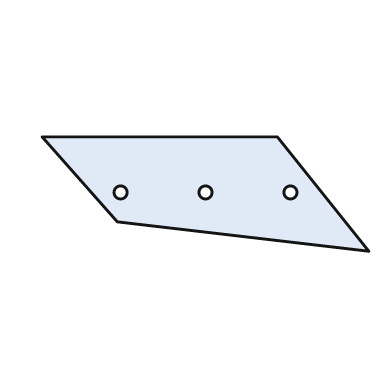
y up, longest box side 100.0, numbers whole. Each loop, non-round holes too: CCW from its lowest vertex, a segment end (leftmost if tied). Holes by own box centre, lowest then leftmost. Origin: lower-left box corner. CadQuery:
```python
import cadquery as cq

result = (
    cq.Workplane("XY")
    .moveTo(100.0, 0.0)
    .lineTo(72.0, 35.0)
    .lineTo(0.0, 35.0)
    .lineTo(23.0, 9.0)
    .close()
    .moveTo(24.0, 18.0)
    .circle(2.0)
    .moveTo(50.0, 18.0)
    .circle(2.0)
    .moveTo(76.0, 18.0)
    .circle(2.0)
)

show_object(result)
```